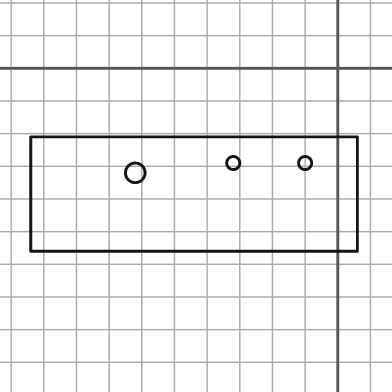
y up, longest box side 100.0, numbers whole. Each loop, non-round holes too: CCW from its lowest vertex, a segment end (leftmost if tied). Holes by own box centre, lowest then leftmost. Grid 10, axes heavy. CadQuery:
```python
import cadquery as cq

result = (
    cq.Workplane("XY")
    .moveTo(-94.0, -56.0)
    .lineTo(6.0, -56.0)
    .lineTo(6.0, -21.0)
    .lineTo(-94.0, -21.0)
    .close()
    .moveTo(-62.0, -32.0)
    .circle(3.0)
    .moveTo(-32.0, -29.0)
    .circle(2.0)
    .moveTo(-10.0, -29.0)
    .circle(2.0)
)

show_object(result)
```